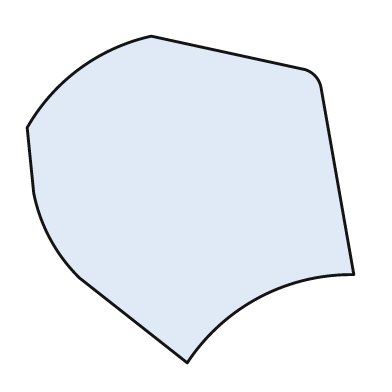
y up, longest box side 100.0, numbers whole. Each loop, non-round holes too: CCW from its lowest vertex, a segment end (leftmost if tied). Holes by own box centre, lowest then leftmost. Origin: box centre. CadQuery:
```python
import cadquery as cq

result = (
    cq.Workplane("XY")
    .moveTo(-1.0, -50.0)
    .threePointArc((21.0, -30.0), (50.0, -23.0))
    .lineTo(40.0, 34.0)
    .threePointArc((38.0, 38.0), (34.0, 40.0))
    .lineTo(-12.0, 50.0)
    .threePointArc((-34.0, 40.0), (-50.0, 22.0))
    .lineTo(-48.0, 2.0)
    .threePointArc((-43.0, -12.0), (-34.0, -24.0))
    .close()
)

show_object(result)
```